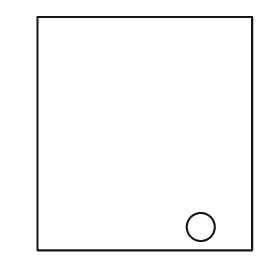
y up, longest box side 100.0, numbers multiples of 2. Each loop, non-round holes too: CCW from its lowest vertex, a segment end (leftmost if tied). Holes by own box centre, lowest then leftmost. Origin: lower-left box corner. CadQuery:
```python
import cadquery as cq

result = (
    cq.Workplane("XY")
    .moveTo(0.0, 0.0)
    .lineTo(92.0, 0.0)
    .lineTo(92.0, 100.0)
    .lineTo(0.0, 100.0)
    .close()
    .moveTo(70.0, 10.0)
    .circle(6.0)
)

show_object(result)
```